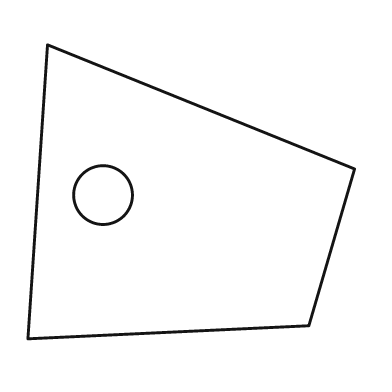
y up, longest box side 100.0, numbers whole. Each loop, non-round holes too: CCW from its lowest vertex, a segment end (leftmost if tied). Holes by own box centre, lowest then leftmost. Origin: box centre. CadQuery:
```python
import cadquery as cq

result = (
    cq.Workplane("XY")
    .moveTo(-50.0, -45.0)
    .lineTo(36.0, -41.0)
    .lineTo(50.0, 7.0)
    .lineTo(-44.0, 45.0)
    .close()
    .moveTo(-27.0, -1.0)
    .circle(9.0)
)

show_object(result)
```